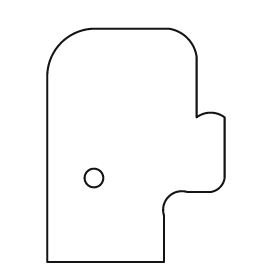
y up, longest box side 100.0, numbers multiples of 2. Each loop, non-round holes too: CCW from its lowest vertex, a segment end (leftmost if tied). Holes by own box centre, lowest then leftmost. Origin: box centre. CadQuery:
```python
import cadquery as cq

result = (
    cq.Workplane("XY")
    .moveTo(-38.0, -50.0)
    .lineTo(12.0, -50.0)
    .lineTo(12.0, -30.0)
    .threePointArc((14.0, -22.0), (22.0, -20.0))
    .lineTo(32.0, -20.0)
    .threePointArc((36.0, -18.0), (38.0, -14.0))
    .lineTo(38.0, 12.0)
    .threePointArc((32.0, 14.0), (26.0, 12.0))
    .lineTo(26.0, 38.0)
    .threePointArc((22.0, 46.0), (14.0, 50.0))
    .lineTo(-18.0, 50.0)
    .threePointArc((-32.0, 44.0), (-38.0, 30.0))
    .close()
    .moveTo(-18.0, -14.0)
    .circle(4.0)
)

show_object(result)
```